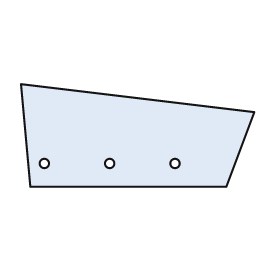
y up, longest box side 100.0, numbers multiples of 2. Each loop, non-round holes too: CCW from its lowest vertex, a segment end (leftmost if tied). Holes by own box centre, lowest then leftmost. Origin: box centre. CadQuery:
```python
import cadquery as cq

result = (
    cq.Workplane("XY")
    .moveTo(-46.0, -22.0)
    .lineTo(38.0, -22.0)
    .lineTo(50.0, 10.0)
    .lineTo(-50.0, 22.0)
    .close()
    .moveTo(-40.0, -12.0)
    .circle(2.0)
    .moveTo(-12.0, -12.0)
    .circle(2.0)
    .moveTo(16.0, -12.0)
    .circle(2.0)
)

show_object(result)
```